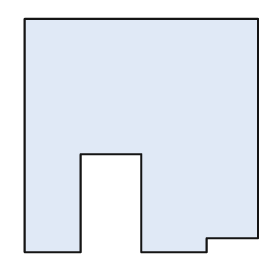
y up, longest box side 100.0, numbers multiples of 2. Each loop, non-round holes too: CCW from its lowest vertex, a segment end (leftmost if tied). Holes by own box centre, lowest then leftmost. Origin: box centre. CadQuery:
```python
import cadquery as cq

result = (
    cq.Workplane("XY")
    .moveTo(-50.0, -50.0)
    .lineTo(-26.0, -50.0)
    .lineTo(-26.0, -8.0)
    .lineTo(0.0, -8.0)
    .lineTo(0.0, -50.0)
    .lineTo(28.0, -50.0)
    .lineTo(28.0, -44.0)
    .lineTo(50.0, -44.0)
    .lineTo(50.0, 50.0)
    .lineTo(-50.0, 50.0)
    .close()
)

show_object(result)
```